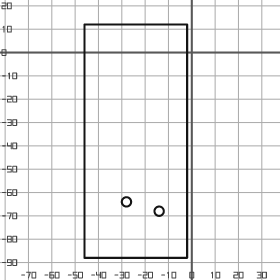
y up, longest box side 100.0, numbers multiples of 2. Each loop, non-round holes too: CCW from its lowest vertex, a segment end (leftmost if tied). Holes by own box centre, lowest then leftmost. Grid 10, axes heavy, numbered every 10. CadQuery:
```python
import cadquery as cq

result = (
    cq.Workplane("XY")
    .moveTo(-46.0, -88.0)
    .lineTo(-2.0, -88.0)
    .lineTo(-2.0, 12.0)
    .lineTo(-46.0, 12.0)
    .close()
    .moveTo(-14.0, -68.0)
    .circle(2.0)
    .moveTo(-28.0, -64.0)
    .circle(2.0)
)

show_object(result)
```